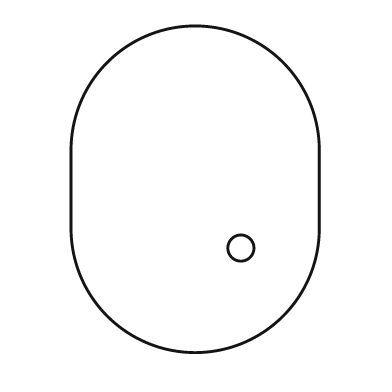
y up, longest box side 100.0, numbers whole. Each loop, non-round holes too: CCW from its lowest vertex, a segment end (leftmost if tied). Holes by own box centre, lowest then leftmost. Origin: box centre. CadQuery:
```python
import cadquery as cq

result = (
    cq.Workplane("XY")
    .moveTo(-38.0, -12.0)
    .threePointArc((0.0, -50.0), (38.0, -12.0))
    .lineTo(38.0, 12.0)
    .threePointArc((0.0, 50.0), (-38.0, 12.0))
    .close()
    .moveTo(14.0, -18.0)
    .circle(4.0)
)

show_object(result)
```